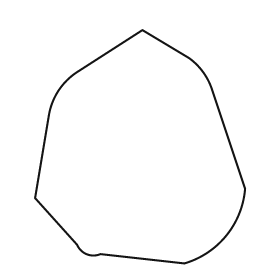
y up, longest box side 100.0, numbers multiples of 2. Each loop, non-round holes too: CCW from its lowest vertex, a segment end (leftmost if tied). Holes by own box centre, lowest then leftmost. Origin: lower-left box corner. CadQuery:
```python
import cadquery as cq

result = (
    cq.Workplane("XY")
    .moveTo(64.0, 0.0)
    .threePointArc((82.0, 12.0), (90.0, 32.0))
    .lineTo(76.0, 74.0)
    .threePointArc((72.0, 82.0), (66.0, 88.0))
    .lineTo(46.0, 100.0)
    .lineTo(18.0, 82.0)
    .threePointArc((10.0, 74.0), (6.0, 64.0))
    .lineTo(0.0, 28.0)
    .lineTo(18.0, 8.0)
    .threePointArc((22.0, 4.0), (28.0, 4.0))
    .close()
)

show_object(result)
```